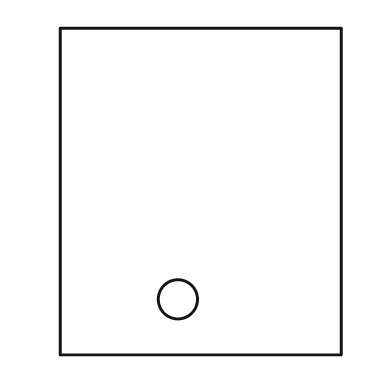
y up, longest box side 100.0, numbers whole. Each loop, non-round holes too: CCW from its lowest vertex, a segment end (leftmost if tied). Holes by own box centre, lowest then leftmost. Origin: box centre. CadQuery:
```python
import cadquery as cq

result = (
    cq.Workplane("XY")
    .moveTo(-43.0, -50.0)
    .lineTo(43.0, -50.0)
    .lineTo(43.0, 50.0)
    .lineTo(-43.0, 50.0)
    .close()
    .moveTo(-7.0, -33.0)
    .circle(6.0)
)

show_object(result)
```